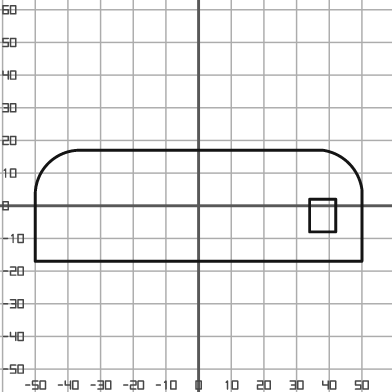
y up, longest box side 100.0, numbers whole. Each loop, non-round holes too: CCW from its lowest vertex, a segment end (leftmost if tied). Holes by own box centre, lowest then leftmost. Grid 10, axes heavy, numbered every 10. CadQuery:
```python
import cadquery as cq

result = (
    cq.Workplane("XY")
    .moveTo(-50.0, -17.0)
    .lineTo(50.0, -17.0)
    .lineTo(50.0, 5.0)
    .threePointArc((46.0, 13.0), (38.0, 17.0))
    .lineTo(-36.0, 17.0)
    .threePointArc((-46.0, 13.0), (-50.0, 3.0))
    .close()
    .moveTo(34.0, -8.0)
    .lineTo(42.0, -8.0)
    .lineTo(42.0, 2.0)
    .lineTo(34.0, 2.0)
    .close()
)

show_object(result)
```